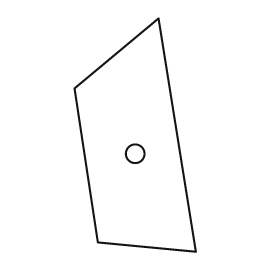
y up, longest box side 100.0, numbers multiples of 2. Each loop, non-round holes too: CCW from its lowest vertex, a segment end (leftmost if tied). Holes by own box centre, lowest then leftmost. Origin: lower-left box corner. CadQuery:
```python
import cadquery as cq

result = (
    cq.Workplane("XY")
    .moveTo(52.0, 0.0)
    .lineTo(36.0, 100.0)
    .lineTo(0.0, 70.0)
    .lineTo(10.0, 4.0)
    .close()
    .moveTo(26.0, 42.0)
    .circle(4.0)
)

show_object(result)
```